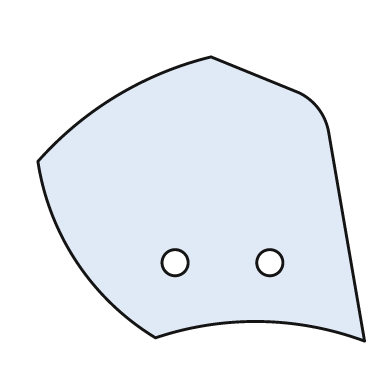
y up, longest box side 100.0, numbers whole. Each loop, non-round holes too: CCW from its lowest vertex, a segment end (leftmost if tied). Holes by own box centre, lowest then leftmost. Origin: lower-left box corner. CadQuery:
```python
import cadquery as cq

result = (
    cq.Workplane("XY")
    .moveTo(100.0, 0.0)
    .lineTo(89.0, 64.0)
    .threePointArc((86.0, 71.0), (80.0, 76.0))
    .lineTo(53.0, 87.0)
    .threePointArc((24.0, 75.0), (0.0, 55.0))
    .threePointArc((12.0, 24.0), (36.0, 1.0))
    .threePointArc((68.0, 6.0), (100.0, 0.0))
    .close()
    .moveTo(42.0, 24.0)
    .circle(4.0)
    .moveTo(71.0, 24.0)
    .circle(4.0)
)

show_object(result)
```